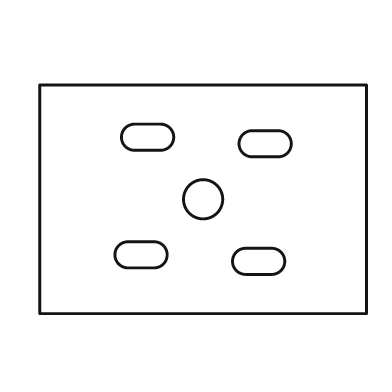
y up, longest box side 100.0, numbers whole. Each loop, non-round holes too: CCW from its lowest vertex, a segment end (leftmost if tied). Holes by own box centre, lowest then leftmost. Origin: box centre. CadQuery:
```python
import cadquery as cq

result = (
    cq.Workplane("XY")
    .moveTo(-50.0, -35.0)
    .lineTo(50.0, -35.0)
    .lineTo(50.0, 35.0)
    .lineTo(-50.0, 35.0)
    .close()
    .moveTo(13.0, -23.0)
    .lineTo(21.0, -23.0)
    .threePointArc((25.0, -19.0), (21.0, -15.0))
    .lineTo(13.0, -15.0)
    .threePointArc((9.0, -19.0), (13.0, -23.0))
    .close()
    .moveTo(-23.0, -21.0)
    .lineTo(-15.0, -21.0)
    .threePointArc((-11.0, -17.0), (-15.0, -13.0))
    .lineTo(-23.0, -13.0)
    .threePointArc((-27.0, -17.0), (-23.0, -21.0))
    .close()
    .moveTo(0.0, 0.0)
    .circle(6.0)
    .moveTo(15.0, 13.0)
    .lineTo(23.0, 13.0)
    .threePointArc((27.0, 17.0), (23.0, 21.0))
    .lineTo(15.0, 21.0)
    .threePointArc((11.0, 17.0), (15.0, 13.0))
    .close()
    .moveTo(-21.0, 15.0)
    .lineTo(-13.0, 15.0)
    .threePointArc((-9.0, 19.0), (-13.0, 23.0))
    .lineTo(-21.0, 23.0)
    .threePointArc((-25.0, 19.0), (-21.0, 15.0))
    .close()
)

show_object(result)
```